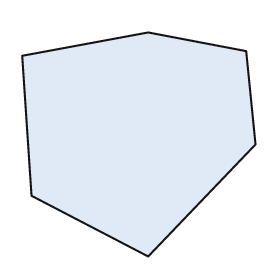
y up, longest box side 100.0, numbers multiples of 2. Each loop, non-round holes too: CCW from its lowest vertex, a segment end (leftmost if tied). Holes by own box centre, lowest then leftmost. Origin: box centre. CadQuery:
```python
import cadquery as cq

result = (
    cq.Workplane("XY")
    .moveTo(4.0, -48.0)
    .lineTo(50.0, 0.0)
    .lineTo(46.0, 40.0)
    .lineTo(4.0, 48.0)
    .lineTo(-50.0, 38.0)
    .lineTo(-46.0, -22.0)
    .close()
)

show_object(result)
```